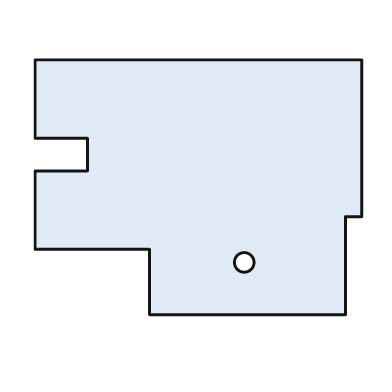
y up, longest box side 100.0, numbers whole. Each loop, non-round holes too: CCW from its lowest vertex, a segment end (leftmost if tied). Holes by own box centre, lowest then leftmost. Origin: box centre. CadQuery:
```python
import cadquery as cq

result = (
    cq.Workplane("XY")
    .moveTo(-15.0, -39.0)
    .lineTo(45.0, -39.0)
    .lineTo(45.0, -9.0)
    .lineTo(50.0, -9.0)
    .lineTo(50.0, 39.0)
    .lineTo(-50.0, 39.0)
    .lineTo(-50.0, 15.0)
    .lineTo(-34.0, 15.0)
    .lineTo(-34.0, 5.0)
    .lineTo(-50.0, 5.0)
    .lineTo(-50.0, -19.0)
    .lineTo(-15.0, -19.0)
    .close()
    .moveTo(14.0, -23.0)
    .circle(3.0)
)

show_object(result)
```